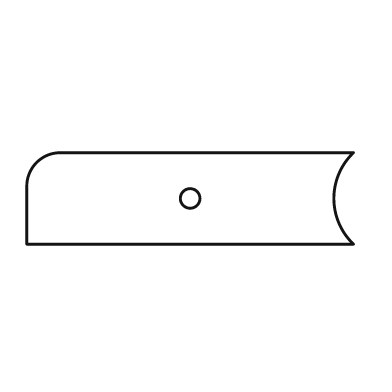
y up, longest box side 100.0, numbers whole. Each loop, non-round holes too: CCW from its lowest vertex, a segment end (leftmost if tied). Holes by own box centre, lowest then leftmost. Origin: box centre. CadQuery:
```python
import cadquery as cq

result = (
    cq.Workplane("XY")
    .moveTo(-50.0, -14.0)
    .lineTo(50.0, -14.0)
    .threePointArc((44.0, 0.0), (50.0, 14.0))
    .lineTo(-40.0, 14.0)
    .threePointArc((-47.0, 11.0), (-50.0, 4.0))
    .close()
    .moveTo(0.0, 0.0)
    .circle(3.0)
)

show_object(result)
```